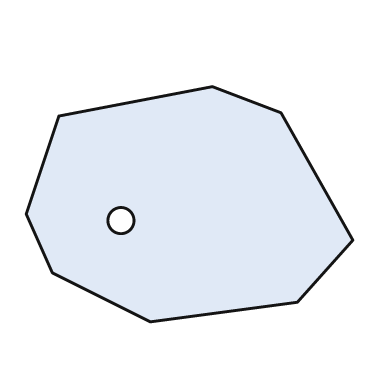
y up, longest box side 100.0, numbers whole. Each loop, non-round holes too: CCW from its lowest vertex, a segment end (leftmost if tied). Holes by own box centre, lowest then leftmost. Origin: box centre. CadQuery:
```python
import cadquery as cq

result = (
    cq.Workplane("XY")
    .moveTo(-12.0, -36.0)
    .lineTo(33.0, -30.0)
    .lineTo(50.0, -11.0)
    .lineTo(28.0, 28.0)
    .lineTo(7.0, 36.0)
    .lineTo(-40.0, 27.0)
    .lineTo(-50.0, -3.0)
    .lineTo(-42.0, -21.0)
    .close()
    .moveTo(-21.0, -5.0)
    .circle(4.0)
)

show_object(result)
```